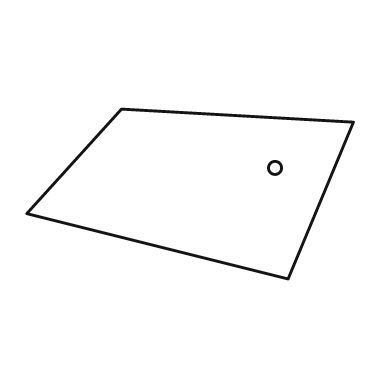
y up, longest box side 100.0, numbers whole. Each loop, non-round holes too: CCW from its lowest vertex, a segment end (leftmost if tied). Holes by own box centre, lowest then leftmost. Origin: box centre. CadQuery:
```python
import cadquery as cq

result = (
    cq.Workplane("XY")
    .moveTo(30.0, -26.0)
    .lineTo(50.0, 22.0)
    .lineTo(-21.0, 26.0)
    .lineTo(-50.0, -6.0)
    .close()
    .moveTo(26.0, 8.0)
    .circle(2.0)
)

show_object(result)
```